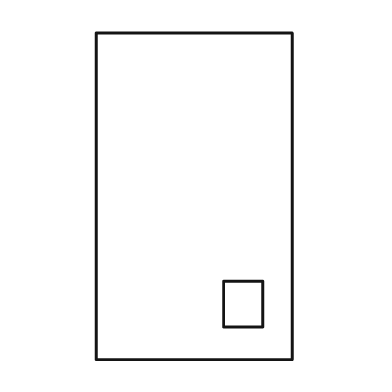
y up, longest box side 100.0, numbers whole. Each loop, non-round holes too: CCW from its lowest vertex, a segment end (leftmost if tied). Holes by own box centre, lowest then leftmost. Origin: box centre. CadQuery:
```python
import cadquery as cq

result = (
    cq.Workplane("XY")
    .moveTo(-30.0, -50.0)
    .lineTo(30.0, -50.0)
    .lineTo(30.0, 50.0)
    .lineTo(-30.0, 50.0)
    .close()
    .moveTo(9.0, -40.0)
    .lineTo(21.0, -40.0)
    .lineTo(21.0, -26.0)
    .lineTo(9.0, -26.0)
    .close()
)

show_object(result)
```